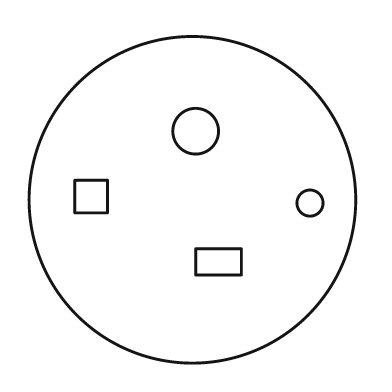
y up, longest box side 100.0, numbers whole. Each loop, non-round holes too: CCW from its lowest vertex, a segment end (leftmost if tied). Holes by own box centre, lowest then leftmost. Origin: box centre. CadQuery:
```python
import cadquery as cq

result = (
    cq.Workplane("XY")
    .moveTo(0.0, 0.0)
    .circle(50.0)
    .moveTo(1.0, -23.0)
    .lineTo(15.0, -23.0)
    .lineTo(15.0, -15.0)
    .lineTo(1.0, -15.0)
    .close()
    .moveTo(36.0, -1.0)
    .circle(4.0)
    .moveTo(-36.0, -4.0)
    .lineTo(-26.0, -4.0)
    .lineTo(-26.0, 6.0)
    .lineTo(-36.0, 6.0)
    .close()
    .moveTo(1.0, 21.0)
    .circle(7.0)
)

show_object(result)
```